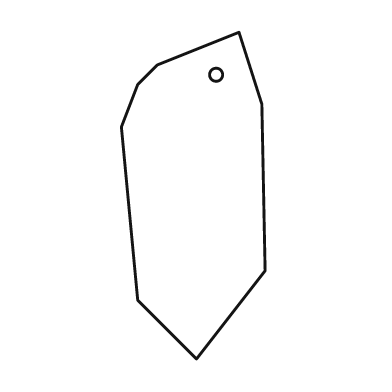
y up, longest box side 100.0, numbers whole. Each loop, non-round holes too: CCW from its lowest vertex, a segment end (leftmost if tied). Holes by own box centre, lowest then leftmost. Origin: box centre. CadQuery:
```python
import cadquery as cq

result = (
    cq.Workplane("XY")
    .moveTo(1.0, -50.0)
    .lineTo(22.0, -23.0)
    .lineTo(21.0, 28.0)
    .lineTo(14.0, 50.0)
    .lineTo(-11.0, 40.0)
    .lineTo(-17.0, 34.0)
    .lineTo(-22.0, 21.0)
    .lineTo(-17.0, -32.0)
    .close()
    .moveTo(7.0, 37.0)
    .circle(2.0)
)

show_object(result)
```